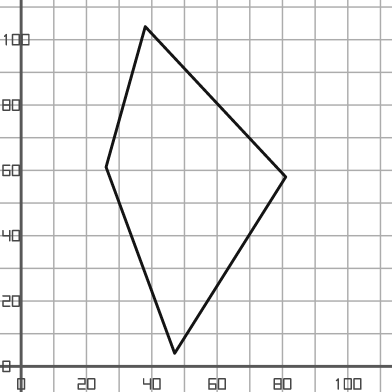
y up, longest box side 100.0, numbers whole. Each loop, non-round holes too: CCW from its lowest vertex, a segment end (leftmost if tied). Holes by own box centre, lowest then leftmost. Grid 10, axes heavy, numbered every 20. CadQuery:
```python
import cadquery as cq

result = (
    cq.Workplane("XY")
    .moveTo(47.0, 4.0)
    .lineTo(81.0, 58.0)
    .lineTo(38.0, 104.0)
    .lineTo(26.0, 61.0)
    .close()
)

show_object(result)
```